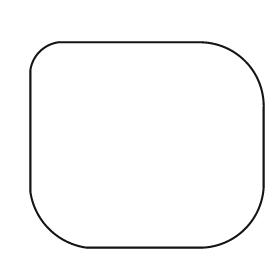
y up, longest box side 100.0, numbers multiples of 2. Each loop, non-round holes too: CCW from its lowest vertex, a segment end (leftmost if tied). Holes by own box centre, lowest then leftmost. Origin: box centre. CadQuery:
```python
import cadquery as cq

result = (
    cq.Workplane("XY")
    .moveTo(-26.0, -44.0)
    .lineTo(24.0, -44.0)
    .threePointArc((42.0, -36.0), (50.0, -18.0))
    .lineTo(50.0, 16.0)
    .threePointArc((42.0, 36.0), (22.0, 44.0))
    .lineTo(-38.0, 44.0)
    .threePointArc((-46.0, 40.0), (-50.0, 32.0))
    .lineTo(-50.0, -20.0)
    .threePointArc((-42.0, -36.0), (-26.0, -44.0))
    .close()
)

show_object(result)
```